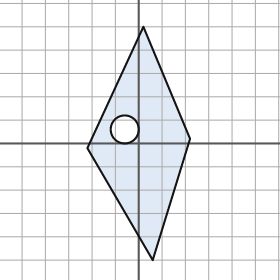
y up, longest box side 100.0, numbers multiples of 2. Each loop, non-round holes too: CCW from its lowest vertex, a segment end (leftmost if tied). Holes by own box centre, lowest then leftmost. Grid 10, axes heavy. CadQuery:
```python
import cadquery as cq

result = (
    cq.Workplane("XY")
    .moveTo(6.0, -50.0)
    .lineTo(22.0, 2.0)
    .lineTo(2.0, 50.0)
    .lineTo(-22.0, -2.0)
    .close()
    .moveTo(-6.0, 6.0)
    .circle(6.0)
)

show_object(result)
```